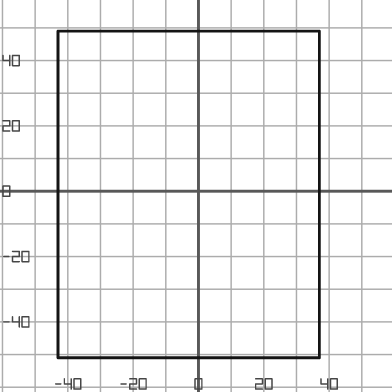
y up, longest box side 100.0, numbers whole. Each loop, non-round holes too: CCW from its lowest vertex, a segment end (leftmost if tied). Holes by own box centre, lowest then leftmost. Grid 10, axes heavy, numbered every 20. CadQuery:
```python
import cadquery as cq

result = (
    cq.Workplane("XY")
    .moveTo(-43.0, -51.0)
    .lineTo(37.0, -51.0)
    .lineTo(37.0, 49.0)
    .lineTo(-43.0, 49.0)
    .close()
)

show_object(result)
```